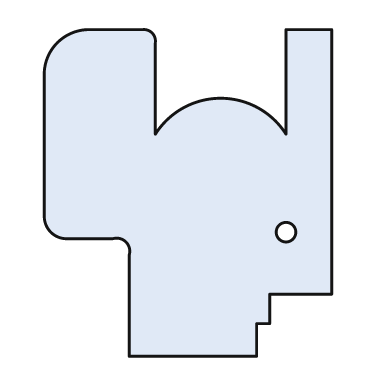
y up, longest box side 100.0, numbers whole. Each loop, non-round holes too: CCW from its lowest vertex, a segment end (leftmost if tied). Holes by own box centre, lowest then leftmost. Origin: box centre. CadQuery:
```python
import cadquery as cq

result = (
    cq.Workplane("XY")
    .moveTo(-18.0, -50.0)
    .lineTo(21.0, -50.0)
    .lineTo(21.0, -40.0)
    .lineTo(25.0, -40.0)
    .lineTo(25.0, -31.0)
    .lineTo(44.0, -31.0)
    .lineTo(44.0, 50.0)
    .lineTo(30.0, 50.0)
    .lineTo(30.0, 18.0)
    .threePointArc((10.0, 29.0), (-10.0, 18.0))
    .lineTo(-10.0, 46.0)
    .threePointArc((-11.0, 49.0), (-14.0, 50.0))
    .lineTo(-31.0, 50.0)
    .threePointArc((-40.0, 46.0), (-44.0, 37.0))
    .lineTo(-44.0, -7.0)
    .threePointArc((-42.0, -12.0), (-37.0, -14.0))
    .lineTo(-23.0, -14.0)
    .threePointArc((-19.0, -15.0), (-18.0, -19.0))
    .close()
    .moveTo(30.0, -12.0)
    .circle(3.0)
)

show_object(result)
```